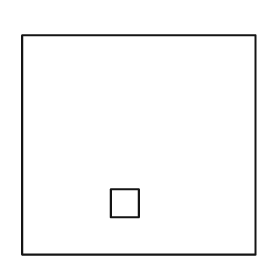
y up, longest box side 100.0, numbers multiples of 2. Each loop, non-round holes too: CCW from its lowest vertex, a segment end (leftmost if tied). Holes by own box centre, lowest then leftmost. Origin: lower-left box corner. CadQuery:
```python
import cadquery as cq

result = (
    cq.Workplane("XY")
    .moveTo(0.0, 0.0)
    .lineTo(100.0, 0.0)
    .lineTo(100.0, 94.0)
    .lineTo(0.0, 94.0)
    .close()
    .moveTo(38.0, 16.0)
    .lineTo(50.0, 16.0)
    .lineTo(50.0, 28.0)
    .lineTo(38.0, 28.0)
    .close()
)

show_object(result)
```